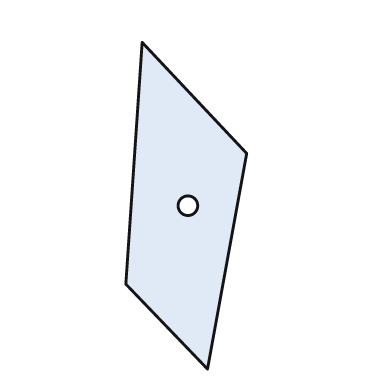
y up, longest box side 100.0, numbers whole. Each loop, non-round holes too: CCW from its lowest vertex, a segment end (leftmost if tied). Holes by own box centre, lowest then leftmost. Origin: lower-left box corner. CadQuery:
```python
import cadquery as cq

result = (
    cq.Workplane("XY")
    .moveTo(25.0, 0.0)
    .lineTo(37.0, 66.0)
    .lineTo(5.0, 100.0)
    .lineTo(0.0, 26.0)
    .close()
    .moveTo(19.0, 50.0)
    .circle(3.0)
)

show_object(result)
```